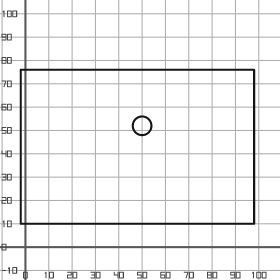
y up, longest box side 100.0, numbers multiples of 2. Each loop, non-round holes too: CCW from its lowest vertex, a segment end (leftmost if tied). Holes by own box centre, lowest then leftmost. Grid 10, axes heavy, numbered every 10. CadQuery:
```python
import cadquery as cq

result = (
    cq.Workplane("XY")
    .moveTo(-2.0, 10.0)
    .lineTo(98.0, 10.0)
    .lineTo(98.0, 76.0)
    .lineTo(-2.0, 76.0)
    .close()
    .moveTo(50.0, 52.0)
    .circle(4.0)
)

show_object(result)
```